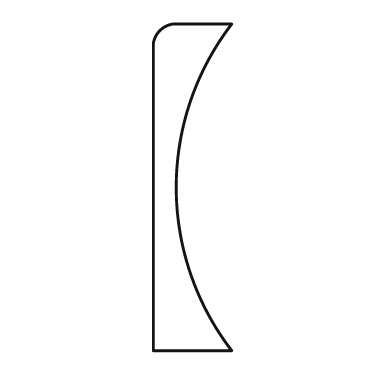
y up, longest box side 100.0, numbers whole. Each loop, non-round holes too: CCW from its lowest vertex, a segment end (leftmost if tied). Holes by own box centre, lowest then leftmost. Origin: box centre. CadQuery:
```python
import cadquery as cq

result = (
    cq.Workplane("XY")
    .moveTo(-12.0, -50.0)
    .lineTo(12.0, -50.0)
    .threePointArc((-5.0, 0.0), (12.0, 50.0))
    .lineTo(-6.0, 50.0)
    .threePointArc((-10.0, 48.0), (-12.0, 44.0))
    .close()
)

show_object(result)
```